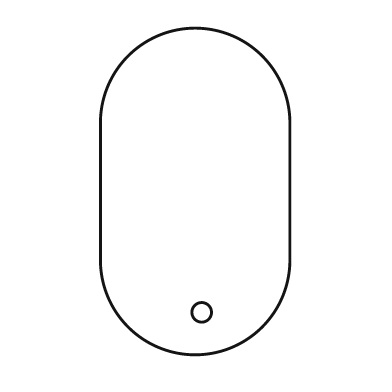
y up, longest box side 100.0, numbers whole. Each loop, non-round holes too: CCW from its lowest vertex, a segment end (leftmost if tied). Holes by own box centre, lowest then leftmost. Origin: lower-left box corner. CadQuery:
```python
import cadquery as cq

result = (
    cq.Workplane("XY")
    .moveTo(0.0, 29.0)
    .threePointArc((29.0, 0.0), (58.0, 29.0))
    .lineTo(58.0, 71.0)
    .threePointArc((29.0, 100.0), (0.0, 71.0))
    .close()
    .moveTo(31.0, 13.0)
    .circle(3.0)
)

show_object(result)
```